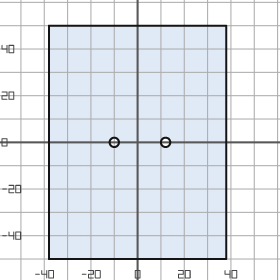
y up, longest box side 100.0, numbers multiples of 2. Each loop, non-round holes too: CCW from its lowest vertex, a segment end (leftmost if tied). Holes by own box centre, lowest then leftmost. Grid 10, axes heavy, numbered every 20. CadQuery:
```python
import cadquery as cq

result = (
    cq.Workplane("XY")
    .moveTo(-38.0, -50.0)
    .lineTo(38.0, -50.0)
    .lineTo(38.0, 50.0)
    .lineTo(-38.0, 50.0)
    .close()
    .moveTo(-10.0, 0.0)
    .circle(2.0)
    .moveTo(12.0, 0.0)
    .circle(2.0)
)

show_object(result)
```